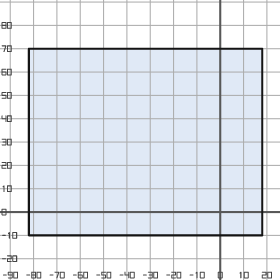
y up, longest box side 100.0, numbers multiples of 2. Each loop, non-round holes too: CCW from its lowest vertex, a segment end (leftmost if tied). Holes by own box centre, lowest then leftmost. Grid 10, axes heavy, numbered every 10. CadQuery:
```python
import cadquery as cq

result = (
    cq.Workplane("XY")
    .moveTo(-82.0, -10.0)
    .lineTo(18.0, -10.0)
    .lineTo(18.0, 70.0)
    .lineTo(-82.0, 70.0)
    .close()
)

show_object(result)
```